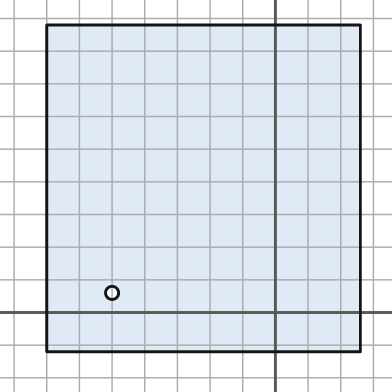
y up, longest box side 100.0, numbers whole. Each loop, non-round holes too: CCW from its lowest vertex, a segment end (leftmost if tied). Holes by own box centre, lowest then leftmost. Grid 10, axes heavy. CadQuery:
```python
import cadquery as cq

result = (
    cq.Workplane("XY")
    .moveTo(-70.0, -12.0)
    .lineTo(26.0, -12.0)
    .lineTo(26.0, 88.0)
    .lineTo(-70.0, 88.0)
    .close()
    .moveTo(-50.0, 6.0)
    .circle(2.0)
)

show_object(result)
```